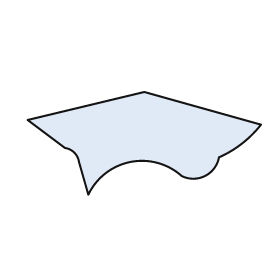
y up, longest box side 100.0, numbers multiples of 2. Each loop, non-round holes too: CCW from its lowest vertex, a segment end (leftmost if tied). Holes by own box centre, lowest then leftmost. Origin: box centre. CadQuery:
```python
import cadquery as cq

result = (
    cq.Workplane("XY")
    .moveTo(-24.0, -22.0)
    .threePointArc((-6.0, -8.0), (16.0, -14.0))
    .threePointArc((26.0, -14.0), (32.0, -6.0))
    .threePointArc((42.0, 0.0), (50.0, 8.0))
    .lineTo(0.0, 22.0)
    .lineTo(-50.0, 10.0)
    .lineTo(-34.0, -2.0)
    .threePointArc((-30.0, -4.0), (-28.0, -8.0))
    .close()
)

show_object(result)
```